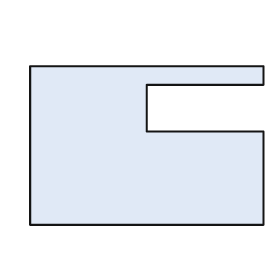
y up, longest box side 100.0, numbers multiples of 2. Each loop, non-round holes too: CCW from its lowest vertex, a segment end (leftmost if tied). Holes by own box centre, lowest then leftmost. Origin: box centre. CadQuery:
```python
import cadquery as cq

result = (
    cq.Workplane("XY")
    .moveTo(-50.0, -34.0)
    .lineTo(50.0, -34.0)
    .lineTo(50.0, 6.0)
    .lineTo(0.0, 6.0)
    .lineTo(0.0, 26.0)
    .lineTo(50.0, 26.0)
    .lineTo(50.0, 34.0)
    .lineTo(-50.0, 34.0)
    .close()
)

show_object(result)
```